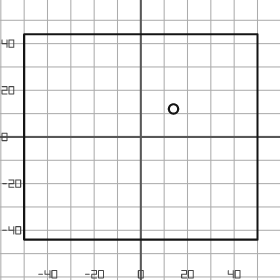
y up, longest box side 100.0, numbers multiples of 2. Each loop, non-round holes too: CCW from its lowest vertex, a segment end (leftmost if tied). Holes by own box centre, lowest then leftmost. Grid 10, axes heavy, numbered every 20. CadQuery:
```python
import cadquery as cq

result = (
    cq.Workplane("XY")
    .moveTo(-50.0, -44.0)
    .lineTo(50.0, -44.0)
    .lineTo(50.0, 44.0)
    .lineTo(-50.0, 44.0)
    .close()
    .moveTo(14.0, 12.0)
    .circle(2.0)
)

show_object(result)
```